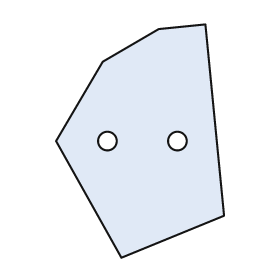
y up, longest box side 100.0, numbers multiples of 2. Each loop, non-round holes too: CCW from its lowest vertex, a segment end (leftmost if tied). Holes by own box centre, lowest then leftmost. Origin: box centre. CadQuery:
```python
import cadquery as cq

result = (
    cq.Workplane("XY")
    .moveTo(-8.0, -50.0)
    .lineTo(36.0, -32.0)
    .lineTo(28.0, 50.0)
    .lineTo(8.0, 48.0)
    .lineTo(-16.0, 34.0)
    .lineTo(-36.0, 0.0)
    .close()
    .moveTo(-14.0, 0.0)
    .circle(4.0)
    .moveTo(16.0, 0.0)
    .circle(4.0)
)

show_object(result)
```